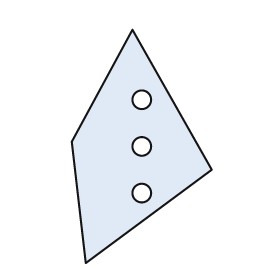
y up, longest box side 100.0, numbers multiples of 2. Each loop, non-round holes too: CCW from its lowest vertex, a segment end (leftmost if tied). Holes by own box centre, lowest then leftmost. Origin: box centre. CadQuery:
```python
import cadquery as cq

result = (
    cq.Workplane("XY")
    .moveTo(-24.0, -50.0)
    .lineTo(30.0, -10.0)
    .lineTo(-4.0, 50.0)
    .lineTo(-30.0, 2.0)
    .close()
    .moveTo(0.0, -20.0)
    .circle(4.0)
    .moveTo(0.0, 0.0)
    .circle(4.0)
    .moveTo(0.0, 20.0)
    .circle(4.0)
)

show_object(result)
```